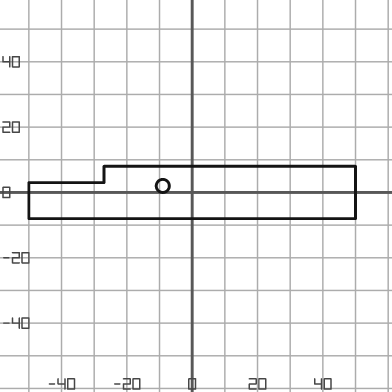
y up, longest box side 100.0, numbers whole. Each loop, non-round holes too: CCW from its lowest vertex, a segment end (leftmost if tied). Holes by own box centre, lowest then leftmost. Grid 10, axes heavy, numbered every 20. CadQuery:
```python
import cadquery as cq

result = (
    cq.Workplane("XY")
    .moveTo(-50.0, -8.0)
    .lineTo(50.0, -8.0)
    .lineTo(50.0, 8.0)
    .lineTo(-27.0, 8.0)
    .lineTo(-27.0, 3.0)
    .lineTo(-50.0, 3.0)
    .close()
    .moveTo(-9.0, 2.0)
    .circle(2.0)
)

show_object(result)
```